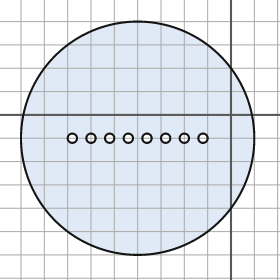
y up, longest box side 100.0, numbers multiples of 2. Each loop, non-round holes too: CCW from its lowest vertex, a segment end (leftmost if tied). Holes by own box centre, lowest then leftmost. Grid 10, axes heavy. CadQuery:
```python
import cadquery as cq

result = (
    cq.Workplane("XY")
    .moveTo(-40.0, -10.0)
    .circle(50.0)
    .moveTo(-68.0, -10.0)
    .circle(2.0)
    .moveTo(-60.0, -10.0)
    .circle(2.0)
    .moveTo(-52.0, -10.0)
    .circle(2.0)
    .moveTo(-44.0, -10.0)
    .circle(2.0)
    .moveTo(-36.0, -10.0)
    .circle(2.0)
    .moveTo(-28.0, -10.0)
    .circle(2.0)
    .moveTo(-20.0, -10.0)
    .circle(2.0)
    .moveTo(-12.0, -10.0)
    .circle(2.0)
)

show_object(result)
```